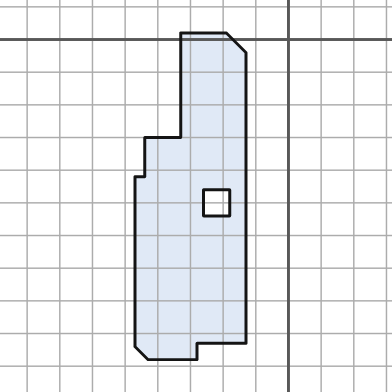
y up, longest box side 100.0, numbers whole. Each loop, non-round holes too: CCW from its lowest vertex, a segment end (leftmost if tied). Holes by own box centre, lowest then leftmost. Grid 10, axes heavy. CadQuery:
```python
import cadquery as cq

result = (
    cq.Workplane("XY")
    .moveTo(-43.0, -98.0)
    .lineTo(-28.0, -98.0)
    .lineTo(-28.0, -93.0)
    .lineTo(-13.0, -93.0)
    .lineTo(-13.0, -4.0)
    .lineTo(-19.0, 2.0)
    .lineTo(-33.0, 2.0)
    .lineTo(-33.0, -30.0)
    .lineTo(-44.0, -30.0)
    .lineTo(-44.0, -42.0)
    .lineTo(-47.0, -42.0)
    .lineTo(-47.0, -94.0)
    .close()
    .moveTo(-26.0, -54.0)
    .lineTo(-18.0, -54.0)
    .lineTo(-18.0, -46.0)
    .lineTo(-26.0, -46.0)
    .close()
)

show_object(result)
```